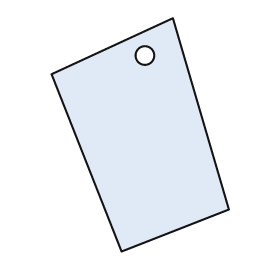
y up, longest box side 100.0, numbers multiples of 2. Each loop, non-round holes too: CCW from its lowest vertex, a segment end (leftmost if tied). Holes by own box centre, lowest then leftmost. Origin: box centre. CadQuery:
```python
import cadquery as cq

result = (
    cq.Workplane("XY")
    .moveTo(-8.0, -50.0)
    .lineTo(38.0, -32.0)
    .lineTo(14.0, 50.0)
    .lineTo(-38.0, 26.0)
    .close()
    .moveTo(2.0, 34.0)
    .circle(4.0)
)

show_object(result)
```